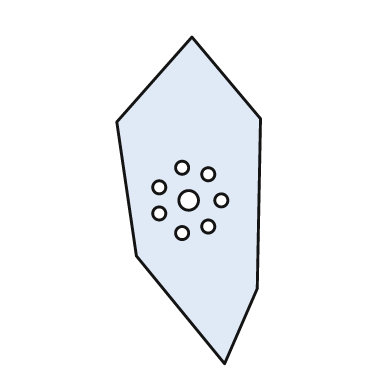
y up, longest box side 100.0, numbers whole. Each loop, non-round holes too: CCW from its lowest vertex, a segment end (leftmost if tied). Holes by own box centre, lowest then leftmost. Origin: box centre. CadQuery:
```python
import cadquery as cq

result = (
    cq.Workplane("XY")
    .moveTo(11.0, -50.0)
    .lineTo(21.0, -27.0)
    .lineTo(22.0, 25.0)
    .lineTo(1.0, 50.0)
    .lineTo(-22.0, 24.0)
    .lineTo(-16.0, -17.0)
    .close()
    .moveTo(-2.0, -10.0)
    .circle(2.0)
    .moveTo(6.0, -8.0)
    .circle(2.0)
    .moveTo(-9.0, -4.0)
    .circle(2.0)
    .moveTo(0.0, 0.0)
    .circle(3.0)
    .moveTo(10.0, 0.0)
    .circle(2.0)
    .moveTo(-9.0, 4.0)
    .circle(2.0)
    .moveTo(6.0, 8.0)
    .circle(2.0)
    .moveTo(-2.0, 10.0)
    .circle(2.0)
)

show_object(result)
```